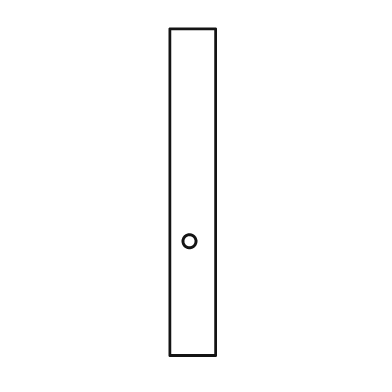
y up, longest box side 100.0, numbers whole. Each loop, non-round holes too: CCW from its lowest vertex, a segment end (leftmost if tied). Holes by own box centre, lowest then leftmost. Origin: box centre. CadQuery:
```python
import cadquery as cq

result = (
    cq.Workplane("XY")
    .moveTo(-7.0, -50.0)
    .lineTo(7.0, -50.0)
    .lineTo(7.0, 50.0)
    .lineTo(-7.0, 50.0)
    .close()
    .moveTo(-1.0, -15.0)
    .circle(2.0)
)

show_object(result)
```